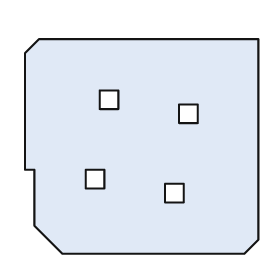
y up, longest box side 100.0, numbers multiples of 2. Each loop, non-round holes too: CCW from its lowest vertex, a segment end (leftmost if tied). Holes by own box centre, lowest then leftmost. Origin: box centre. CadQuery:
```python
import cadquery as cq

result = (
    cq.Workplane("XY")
    .moveTo(-34.0, -46.0)
    .lineTo(44.0, -46.0)
    .lineTo(50.0, -40.0)
    .lineTo(50.0, 46.0)
    .lineTo(-44.0, 46.0)
    .lineTo(-50.0, 40.0)
    .lineTo(-50.0, -10.0)
    .lineTo(-46.0, -10.0)
    .lineTo(-46.0, -34.0)
    .close()
    .moveTo(10.0, -24.0)
    .lineTo(18.0, -24.0)
    .lineTo(18.0, -16.0)
    .lineTo(10.0, -16.0)
    .close()
    .moveTo(-24.0, -18.0)
    .lineTo(-16.0, -18.0)
    .lineTo(-16.0, -10.0)
    .lineTo(-24.0, -10.0)
    .close()
    .moveTo(16.0, 10.0)
    .lineTo(24.0, 10.0)
    .lineTo(24.0, 18.0)
    .lineTo(16.0, 18.0)
    .close()
    .moveTo(-18.0, 16.0)
    .lineTo(-10.0, 16.0)
    .lineTo(-10.0, 24.0)
    .lineTo(-18.0, 24.0)
    .close()
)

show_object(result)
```